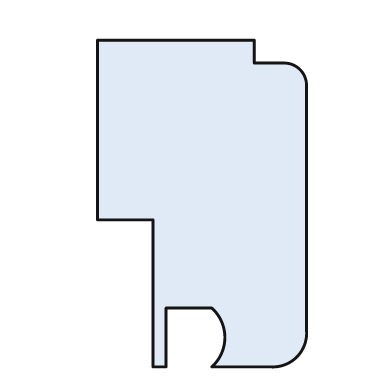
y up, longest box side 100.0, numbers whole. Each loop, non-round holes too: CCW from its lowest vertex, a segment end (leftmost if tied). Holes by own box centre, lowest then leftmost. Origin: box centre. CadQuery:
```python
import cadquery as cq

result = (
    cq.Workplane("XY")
    .moveTo(-15.0, -50.0)
    .lineTo(-11.0, -50.0)
    .lineTo(-11.0, -32.0)
    .lineTo(3.0, -32.0)
    .threePointArc((7.0, -41.0), (3.0, -50.0))
    .lineTo(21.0, -50.0)
    .threePointArc((29.0, -47.0), (32.0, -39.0))
    .lineTo(32.0, 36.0)
    .threePointArc((30.0, 41.0), (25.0, 43.0))
    .lineTo(16.0, 43.0)
    .lineTo(16.0, 50.0)
    .lineTo(-32.0, 50.0)
    .lineTo(-32.0, -5.0)
    .lineTo(-15.0, -5.0)
    .close()
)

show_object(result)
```